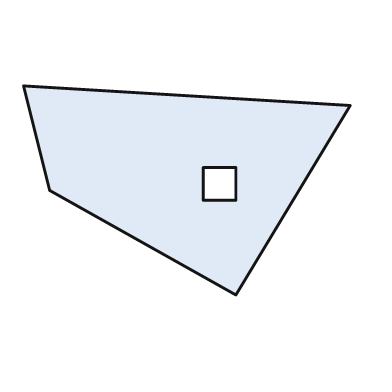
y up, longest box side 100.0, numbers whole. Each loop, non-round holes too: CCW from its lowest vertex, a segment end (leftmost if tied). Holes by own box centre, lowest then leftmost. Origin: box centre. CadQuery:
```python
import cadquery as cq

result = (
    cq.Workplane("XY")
    .moveTo(15.0, -32.0)
    .lineTo(50.0, 26.0)
    .lineTo(-50.0, 32.0)
    .lineTo(-42.0, 0.0)
    .close()
    .moveTo(5.0, -3.0)
    .lineTo(15.0, -3.0)
    .lineTo(15.0, 7.0)
    .lineTo(5.0, 7.0)
    .close()
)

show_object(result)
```